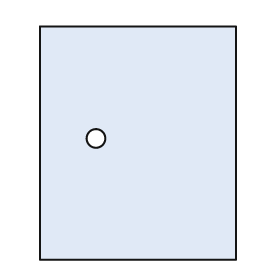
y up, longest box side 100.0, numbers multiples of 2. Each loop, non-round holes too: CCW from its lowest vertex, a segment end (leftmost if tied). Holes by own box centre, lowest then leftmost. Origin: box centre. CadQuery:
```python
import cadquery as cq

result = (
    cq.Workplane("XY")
    .moveTo(-42.0, -50.0)
    .lineTo(42.0, -50.0)
    .lineTo(42.0, 50.0)
    .lineTo(-42.0, 50.0)
    .close()
    .moveTo(-18.0, 2.0)
    .circle(4.0)
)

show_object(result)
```